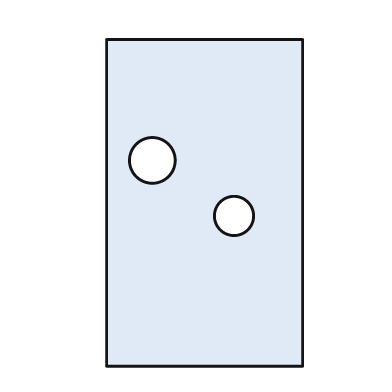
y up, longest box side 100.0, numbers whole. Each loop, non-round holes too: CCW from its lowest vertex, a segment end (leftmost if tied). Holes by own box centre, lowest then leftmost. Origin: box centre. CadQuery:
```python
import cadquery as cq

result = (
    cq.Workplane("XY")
    .moveTo(-30.0, -50.0)
    .lineTo(30.0, -50.0)
    .lineTo(30.0, 50.0)
    .lineTo(-30.0, 50.0)
    .close()
    .moveTo(9.0, -4.0)
    .circle(6.0)
    .moveTo(-16.0, 13.0)
    .circle(7.0)
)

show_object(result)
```